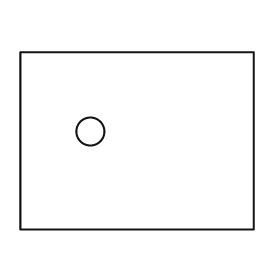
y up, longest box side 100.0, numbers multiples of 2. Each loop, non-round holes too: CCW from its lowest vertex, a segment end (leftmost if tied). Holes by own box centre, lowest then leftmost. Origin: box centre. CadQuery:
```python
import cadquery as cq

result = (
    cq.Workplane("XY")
    .moveTo(-50.0, -38.0)
    .lineTo(50.0, -38.0)
    .lineTo(50.0, 38.0)
    .lineTo(-50.0, 38.0)
    .close()
    .moveTo(-20.0, 4.0)
    .circle(6.0)
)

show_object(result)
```